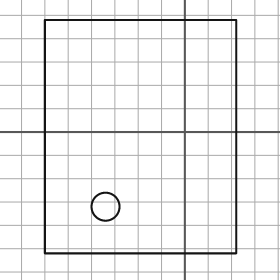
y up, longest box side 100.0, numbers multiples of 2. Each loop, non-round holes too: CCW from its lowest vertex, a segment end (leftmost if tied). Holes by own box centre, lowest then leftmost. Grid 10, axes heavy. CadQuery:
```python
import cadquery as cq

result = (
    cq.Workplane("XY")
    .moveTo(-60.0, -52.0)
    .lineTo(22.0, -52.0)
    .lineTo(22.0, 48.0)
    .lineTo(-60.0, 48.0)
    .close()
    .moveTo(-34.0, -32.0)
    .circle(6.0)
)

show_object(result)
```